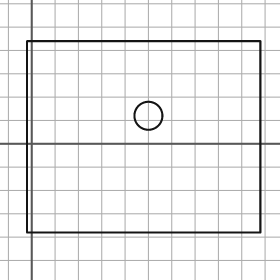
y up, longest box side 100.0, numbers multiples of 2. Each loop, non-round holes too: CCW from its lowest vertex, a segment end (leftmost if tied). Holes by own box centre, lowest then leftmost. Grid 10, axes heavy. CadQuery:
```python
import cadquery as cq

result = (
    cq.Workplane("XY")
    .moveTo(-2.0, -38.0)
    .lineTo(98.0, -38.0)
    .lineTo(98.0, 44.0)
    .lineTo(-2.0, 44.0)
    .close()
    .moveTo(50.0, 12.0)
    .circle(6.0)
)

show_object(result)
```